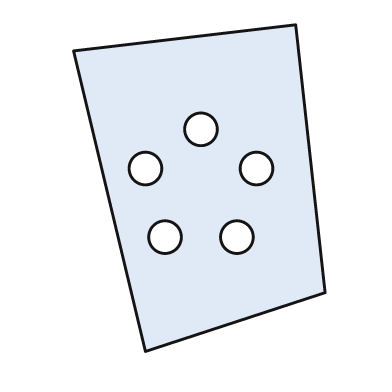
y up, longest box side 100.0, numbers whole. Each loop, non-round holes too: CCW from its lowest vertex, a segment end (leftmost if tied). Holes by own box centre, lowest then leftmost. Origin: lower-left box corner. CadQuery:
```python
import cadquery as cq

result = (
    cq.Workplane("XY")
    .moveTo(22.0, 0.0)
    .lineTo(77.0, 18.0)
    .lineTo(68.0, 100.0)
    .lineTo(0.0, 92.0)
    .close()
    .moveTo(28.0, 35.0)
    .circle(5.0)
    .moveTo(50.0, 35.0)
    .circle(5.0)
    .moveTo(22.0, 56.0)
    .circle(5.0)
    .moveTo(56.0, 56.0)
    .circle(5.0)
    .moveTo(39.0, 68.0)
    .circle(5.0)
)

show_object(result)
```